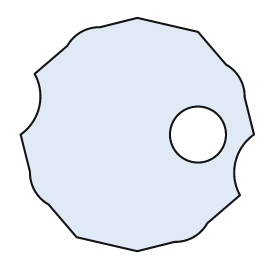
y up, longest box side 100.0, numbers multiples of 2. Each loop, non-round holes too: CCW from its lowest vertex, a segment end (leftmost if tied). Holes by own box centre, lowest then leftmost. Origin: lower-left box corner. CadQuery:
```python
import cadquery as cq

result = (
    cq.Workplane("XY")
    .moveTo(50.0, 0.0)
    .lineTo(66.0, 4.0)
    .threePointArc((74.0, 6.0), (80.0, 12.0))
    .lineTo(94.0, 24.0)
    .threePointArc((92.0, 38.0), (100.0, 50.0))
    .lineTo(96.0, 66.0)
    .threePointArc((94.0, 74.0), (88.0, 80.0))
    .lineTo(76.0, 94.0)
    .lineTo(50.0, 100.0)
    .lineTo(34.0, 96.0)
    .threePointArc((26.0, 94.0), (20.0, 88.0))
    .lineTo(6.0, 76.0)
    .threePointArc((8.0, 62.0), (0.0, 50.0))
    .lineTo(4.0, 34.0)
    .threePointArc((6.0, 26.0), (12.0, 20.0))
    .lineTo(24.0, 6.0)
    .close()
    .moveTo(76.0, 50.0)
    .circle(12.0)
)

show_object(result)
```